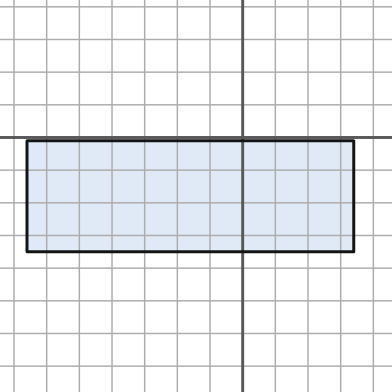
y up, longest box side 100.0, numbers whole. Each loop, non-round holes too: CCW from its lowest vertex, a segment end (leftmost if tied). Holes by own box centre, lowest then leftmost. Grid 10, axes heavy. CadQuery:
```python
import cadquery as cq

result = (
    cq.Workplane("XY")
    .moveTo(-66.0, -35.0)
    .lineTo(34.0, -35.0)
    .lineTo(34.0, -1.0)
    .lineTo(-66.0, -1.0)
    .close()
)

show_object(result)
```